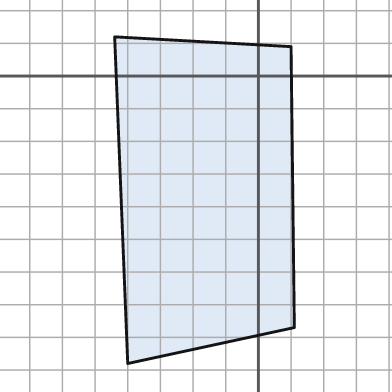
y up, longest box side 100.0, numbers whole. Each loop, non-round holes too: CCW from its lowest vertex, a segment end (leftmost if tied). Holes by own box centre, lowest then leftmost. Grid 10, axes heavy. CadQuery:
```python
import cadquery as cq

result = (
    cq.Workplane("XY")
    .moveTo(-40.0, -88.0)
    .lineTo(11.0, -77.0)
    .lineTo(10.0, 9.0)
    .lineTo(-44.0, 12.0)
    .close()
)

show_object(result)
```